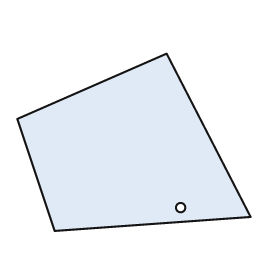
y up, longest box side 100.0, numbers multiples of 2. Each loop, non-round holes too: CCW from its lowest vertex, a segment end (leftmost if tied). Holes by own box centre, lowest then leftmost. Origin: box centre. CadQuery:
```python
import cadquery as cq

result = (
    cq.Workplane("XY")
    .moveTo(-34.0, -38.0)
    .lineTo(50.0, -32.0)
    .lineTo(14.0, 38.0)
    .lineTo(-50.0, 10.0)
    .close()
    .moveTo(20.0, -28.0)
    .circle(2.0)
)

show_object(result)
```